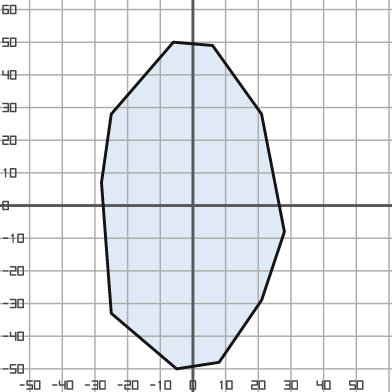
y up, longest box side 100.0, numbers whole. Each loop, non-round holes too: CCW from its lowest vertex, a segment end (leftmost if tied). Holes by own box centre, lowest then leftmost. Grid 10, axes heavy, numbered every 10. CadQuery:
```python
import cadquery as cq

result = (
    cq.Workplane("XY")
    .moveTo(-5.0, -50.0)
    .lineTo(8.0, -48.0)
    .lineTo(21.0, -29.0)
    .lineTo(28.0, -8.0)
    .lineTo(21.0, 28.0)
    .lineTo(6.0, 49.0)
    .lineTo(-6.0, 50.0)
    .lineTo(-25.0, 28.0)
    .lineTo(-28.0, 7.0)
    .lineTo(-25.0, -33.0)
    .close()
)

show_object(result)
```